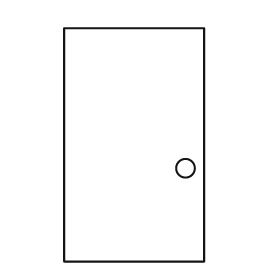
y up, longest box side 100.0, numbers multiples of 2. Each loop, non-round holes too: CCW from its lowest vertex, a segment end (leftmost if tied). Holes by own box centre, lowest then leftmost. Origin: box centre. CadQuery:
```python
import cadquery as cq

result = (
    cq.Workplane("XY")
    .moveTo(-30.0, -50.0)
    .lineTo(30.0, -50.0)
    .lineTo(30.0, 50.0)
    .lineTo(-30.0, 50.0)
    .close()
    .moveTo(22.0, -10.0)
    .circle(4.0)
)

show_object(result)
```